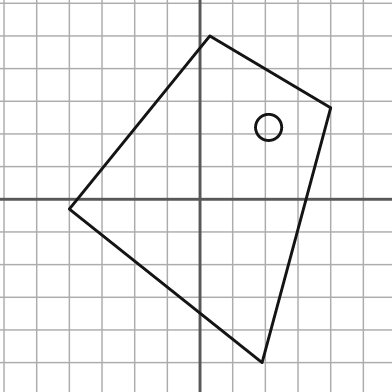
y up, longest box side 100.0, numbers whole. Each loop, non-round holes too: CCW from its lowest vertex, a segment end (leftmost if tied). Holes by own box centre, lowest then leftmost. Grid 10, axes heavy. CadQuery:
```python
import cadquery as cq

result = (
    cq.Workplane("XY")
    .moveTo(19.0, -50.0)
    .lineTo(40.0, 28.0)
    .lineTo(3.0, 50.0)
    .lineTo(-40.0, -3.0)
    .close()
    .moveTo(21.0, 22.0)
    .circle(4.0)
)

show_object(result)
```